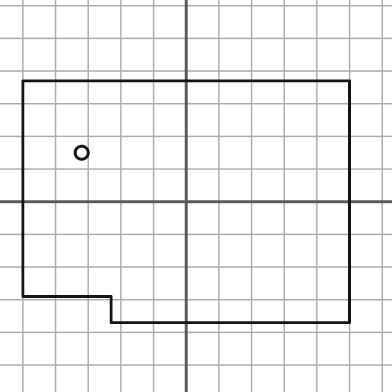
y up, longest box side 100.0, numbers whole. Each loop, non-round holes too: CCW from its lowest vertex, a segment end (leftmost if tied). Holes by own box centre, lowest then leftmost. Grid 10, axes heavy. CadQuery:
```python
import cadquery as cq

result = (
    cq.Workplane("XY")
    .moveTo(-23.0, -37.0)
    .lineTo(50.0, -37.0)
    .lineTo(50.0, 37.0)
    .lineTo(-50.0, 37.0)
    .lineTo(-50.0, -29.0)
    .lineTo(-23.0, -29.0)
    .close()
    .moveTo(-32.0, 15.0)
    .circle(2.0)
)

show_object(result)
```